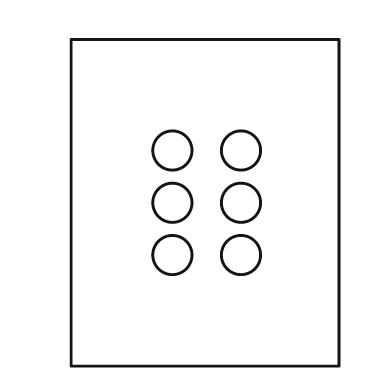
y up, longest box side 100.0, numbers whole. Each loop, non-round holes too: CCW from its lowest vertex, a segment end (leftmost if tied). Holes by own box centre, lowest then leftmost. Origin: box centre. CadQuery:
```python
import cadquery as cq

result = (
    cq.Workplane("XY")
    .moveTo(-41.0, -50.0)
    .lineTo(41.0, -50.0)
    .lineTo(41.0, 50.0)
    .lineTo(-41.0, 50.0)
    .close()
    .moveTo(-10.0, -16.0)
    .circle(6.0)
    .moveTo(11.0, -16.0)
    .circle(6.0)
    .moveTo(-10.0, 0.0)
    .circle(6.0)
    .moveTo(11.0, 0.0)
    .circle(6.0)
    .moveTo(-10.0, 16.0)
    .circle(6.0)
    .moveTo(11.0, 16.0)
    .circle(6.0)
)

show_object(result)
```